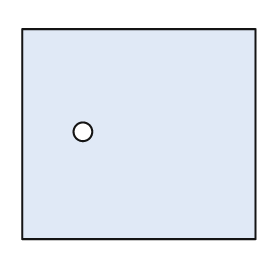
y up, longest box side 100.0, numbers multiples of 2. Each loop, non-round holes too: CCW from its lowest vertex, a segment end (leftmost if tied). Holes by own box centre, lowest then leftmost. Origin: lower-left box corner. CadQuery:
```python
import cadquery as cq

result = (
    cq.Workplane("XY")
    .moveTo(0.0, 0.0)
    .lineTo(100.0, 0.0)
    .lineTo(100.0, 90.0)
    .lineTo(0.0, 90.0)
    .close()
    .moveTo(26.0, 46.0)
    .circle(4.0)
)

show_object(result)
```